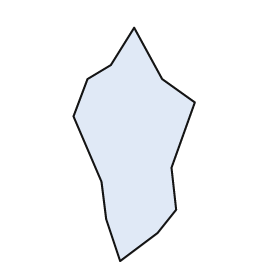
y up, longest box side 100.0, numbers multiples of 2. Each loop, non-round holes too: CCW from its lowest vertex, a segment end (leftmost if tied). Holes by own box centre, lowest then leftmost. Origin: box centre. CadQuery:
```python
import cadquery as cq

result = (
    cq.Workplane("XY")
    .moveTo(-6.0, -50.0)
    .lineTo(10.0, -38.0)
    .lineTo(18.0, -28.0)
    .lineTo(16.0, -10.0)
    .lineTo(26.0, 18.0)
    .lineTo(12.0, 28.0)
    .lineTo(0.0, 50.0)
    .lineTo(-10.0, 34.0)
    .lineTo(-20.0, 28.0)
    .lineTo(-26.0, 12.0)
    .lineTo(-14.0, -16.0)
    .lineTo(-12.0, -32.0)
    .close()
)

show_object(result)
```